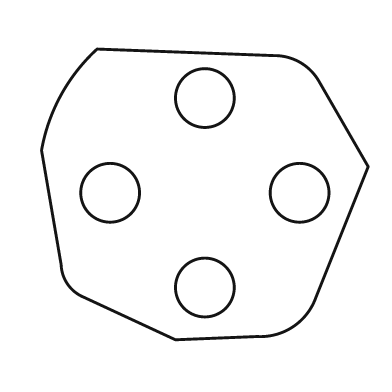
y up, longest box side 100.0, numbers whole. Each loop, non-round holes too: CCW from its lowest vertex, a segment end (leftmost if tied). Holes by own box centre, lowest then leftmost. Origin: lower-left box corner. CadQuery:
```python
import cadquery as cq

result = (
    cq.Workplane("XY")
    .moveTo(41.0, 0.0)
    .lineTo(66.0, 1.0)
    .threePointArc((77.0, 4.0), (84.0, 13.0))
    .lineTo(100.0, 53.0)
    .lineTo(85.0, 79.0)
    .threePointArc((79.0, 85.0), (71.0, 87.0))
    .lineTo(17.0, 89.0)
    .threePointArc((6.0, 75.0), (0.0, 58.0))
    .lineTo(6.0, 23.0)
    .threePointArc((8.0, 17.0), (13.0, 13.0))
    .close()
    .moveTo(50.0, 16.0)
    .circle(9.0)
    .moveTo(21.0, 45.0)
    .circle(9.0)
    .moveTo(79.0, 45.0)
    .circle(9.0)
    .moveTo(50.0, 74.0)
    .circle(9.0)
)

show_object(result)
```